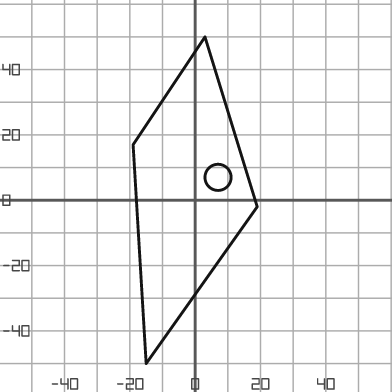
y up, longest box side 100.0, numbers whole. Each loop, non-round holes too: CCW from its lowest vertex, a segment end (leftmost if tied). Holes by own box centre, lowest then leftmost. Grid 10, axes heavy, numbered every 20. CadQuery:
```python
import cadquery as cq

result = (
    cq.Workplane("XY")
    .moveTo(-15.0, -50.0)
    .lineTo(19.0, -2.0)
    .lineTo(3.0, 50.0)
    .lineTo(-19.0, 17.0)
    .close()
    .moveTo(7.0, 7.0)
    .circle(4.0)
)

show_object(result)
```